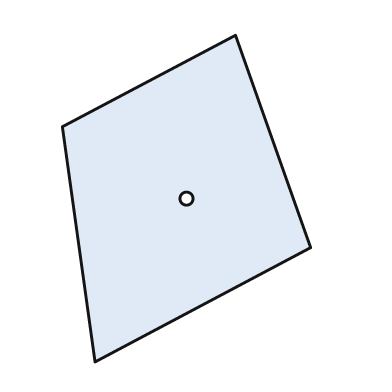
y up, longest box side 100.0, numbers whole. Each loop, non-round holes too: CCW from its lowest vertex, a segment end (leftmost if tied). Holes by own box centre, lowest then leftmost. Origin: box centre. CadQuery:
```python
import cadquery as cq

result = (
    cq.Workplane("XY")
    .moveTo(-28.0, -50.0)
    .lineTo(38.0, -15.0)
    .lineTo(15.0, 50.0)
    .lineTo(-38.0, 22.0)
    .close()
    .moveTo(0.0, 0.0)
    .circle(2.0)
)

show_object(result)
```